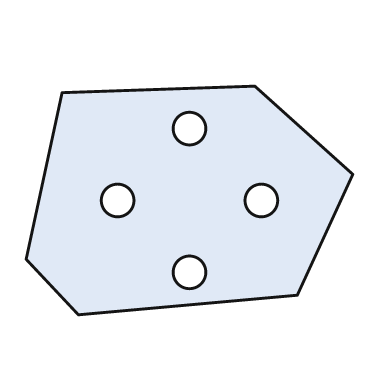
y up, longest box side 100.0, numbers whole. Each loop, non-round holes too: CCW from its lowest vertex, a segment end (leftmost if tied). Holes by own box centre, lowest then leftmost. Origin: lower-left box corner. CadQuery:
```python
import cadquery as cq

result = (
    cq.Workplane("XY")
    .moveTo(16.0, 0.0)
    .lineTo(83.0, 6.0)
    .lineTo(100.0, 43.0)
    .lineTo(70.0, 70.0)
    .lineTo(11.0, 68.0)
    .lineTo(0.0, 17.0)
    .close()
    .moveTo(50.0, 13.0)
    .circle(5.0)
    .moveTo(28.0, 35.0)
    .circle(5.0)
    .moveTo(72.0, 35.0)
    .circle(5.0)
    .moveTo(50.0, 57.0)
    .circle(5.0)
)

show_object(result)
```